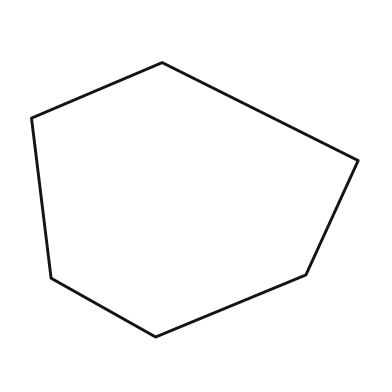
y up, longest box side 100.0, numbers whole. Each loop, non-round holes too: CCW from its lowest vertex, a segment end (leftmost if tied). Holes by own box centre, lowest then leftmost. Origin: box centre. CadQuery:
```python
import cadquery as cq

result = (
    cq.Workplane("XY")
    .moveTo(-12.0, -42.0)
    .lineTo(34.0, -23.0)
    .lineTo(50.0, 12.0)
    .lineTo(-10.0, 42.0)
    .lineTo(-50.0, 25.0)
    .lineTo(-44.0, -24.0)
    .close()
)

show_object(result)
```